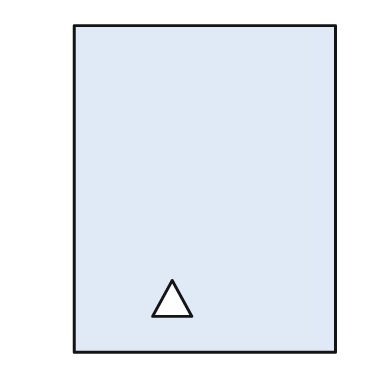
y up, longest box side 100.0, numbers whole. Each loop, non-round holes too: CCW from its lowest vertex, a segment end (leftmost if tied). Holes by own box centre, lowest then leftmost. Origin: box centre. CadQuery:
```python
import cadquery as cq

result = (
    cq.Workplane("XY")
    .moveTo(-40.0, -50.0)
    .lineTo(40.0, -50.0)
    .lineTo(40.0, 50.0)
    .lineTo(-40.0, 50.0)
    .close()
    .moveTo(-16.0, -39.0)
    .lineTo(-4.0, -39.0)
    .lineTo(-10.0, -28.0)
    .close()
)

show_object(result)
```